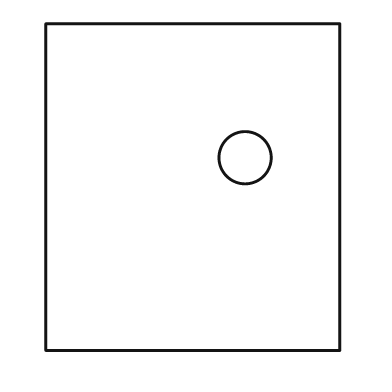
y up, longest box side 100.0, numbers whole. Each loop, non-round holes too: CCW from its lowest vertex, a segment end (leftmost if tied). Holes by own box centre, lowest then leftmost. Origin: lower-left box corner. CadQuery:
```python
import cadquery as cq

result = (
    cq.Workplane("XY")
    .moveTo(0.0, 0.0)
    .lineTo(90.0, 0.0)
    .lineTo(90.0, 100.0)
    .lineTo(0.0, 100.0)
    .close()
    .moveTo(61.0, 59.0)
    .circle(8.0)
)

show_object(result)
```